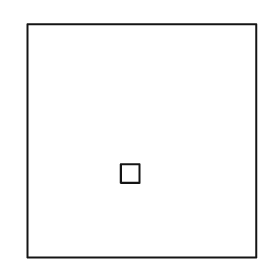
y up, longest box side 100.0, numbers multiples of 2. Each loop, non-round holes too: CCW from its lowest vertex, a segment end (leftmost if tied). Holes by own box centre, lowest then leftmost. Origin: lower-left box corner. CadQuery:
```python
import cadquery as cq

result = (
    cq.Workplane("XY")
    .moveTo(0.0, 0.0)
    .lineTo(98.0, 0.0)
    .lineTo(98.0, 100.0)
    .lineTo(0.0, 100.0)
    .close()
    .moveTo(40.0, 32.0)
    .lineTo(48.0, 32.0)
    .lineTo(48.0, 40.0)
    .lineTo(40.0, 40.0)
    .close()
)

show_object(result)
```